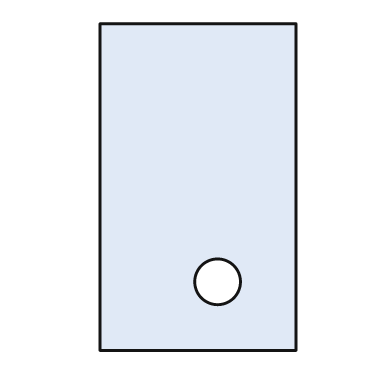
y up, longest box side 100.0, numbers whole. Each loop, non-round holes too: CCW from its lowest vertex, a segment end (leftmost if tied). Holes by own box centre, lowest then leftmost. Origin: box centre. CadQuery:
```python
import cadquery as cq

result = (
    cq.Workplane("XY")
    .moveTo(-30.0, -50.0)
    .lineTo(30.0, -50.0)
    .lineTo(30.0, 50.0)
    .lineTo(-30.0, 50.0)
    .close()
    .moveTo(6.0, -29.0)
    .circle(7.0)
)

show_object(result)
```